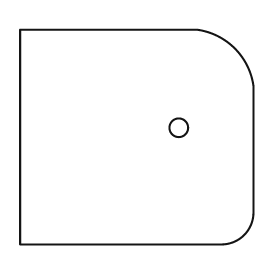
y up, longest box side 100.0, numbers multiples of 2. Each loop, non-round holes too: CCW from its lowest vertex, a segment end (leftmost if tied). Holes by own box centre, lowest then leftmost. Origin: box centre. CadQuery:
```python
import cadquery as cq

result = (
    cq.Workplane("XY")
    .moveTo(-50.0, -46.0)
    .lineTo(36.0, -46.0)
    .threePointArc((46.0, -42.0), (50.0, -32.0))
    .lineTo(50.0, 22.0)
    .threePointArc((42.0, 38.0), (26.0, 46.0))
    .lineTo(-50.0, 46.0)
    .close()
    .moveTo(18.0, 4.0)
    .circle(4.0)
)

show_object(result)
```